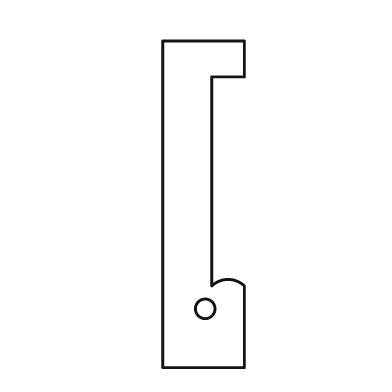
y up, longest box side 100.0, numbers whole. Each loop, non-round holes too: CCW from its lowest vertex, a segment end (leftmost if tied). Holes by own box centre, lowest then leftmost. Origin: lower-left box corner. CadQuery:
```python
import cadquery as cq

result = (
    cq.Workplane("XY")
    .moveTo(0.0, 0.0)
    .lineTo(25.0, 0.0)
    .lineTo(25.0, 25.0)
    .threePointArc((20.0, 27.0), (15.0, 25.0))
    .lineTo(15.0, 89.0)
    .lineTo(25.0, 89.0)
    .lineTo(25.0, 100.0)
    .lineTo(0.0, 100.0)
    .close()
    .moveTo(13.0, 18.0)
    .circle(3.0)
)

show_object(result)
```